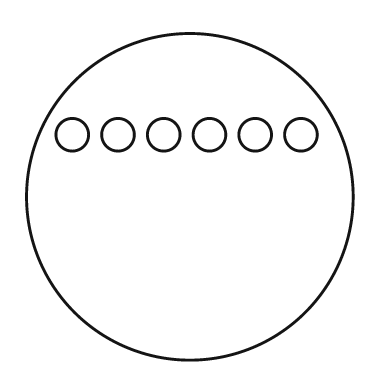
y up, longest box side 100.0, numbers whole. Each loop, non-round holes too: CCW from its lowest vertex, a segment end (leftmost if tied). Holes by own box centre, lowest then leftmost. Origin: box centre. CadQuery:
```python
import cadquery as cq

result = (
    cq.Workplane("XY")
    .moveTo(0.0, 0.0)
    .circle(50.0)
    .moveTo(-36.0, 19.0)
    .circle(5.0)
    .moveTo(-22.0, 19.0)
    .circle(5.0)
    .moveTo(-8.0, 19.0)
    .circle(5.0)
    .moveTo(6.0, 19.0)
    .circle(5.0)
    .moveTo(20.0, 19.0)
    .circle(5.0)
    .moveTo(34.0, 19.0)
    .circle(5.0)
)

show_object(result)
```